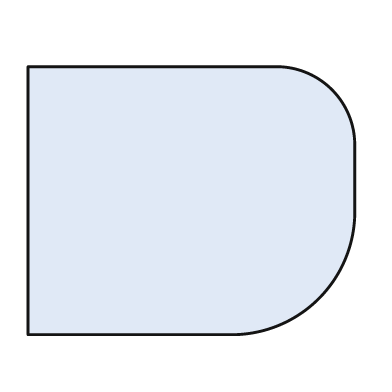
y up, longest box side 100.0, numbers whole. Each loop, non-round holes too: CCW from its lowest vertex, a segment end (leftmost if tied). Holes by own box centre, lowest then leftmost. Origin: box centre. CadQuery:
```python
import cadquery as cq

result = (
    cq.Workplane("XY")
    .moveTo(-50.0, -41.0)
    .lineTo(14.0, -41.0)
    .threePointArc((39.0, -30.0), (50.0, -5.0))
    .lineTo(50.0, 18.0)
    .threePointArc((43.0, 34.0), (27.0, 41.0))
    .lineTo(-50.0, 41.0)
    .close()
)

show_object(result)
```